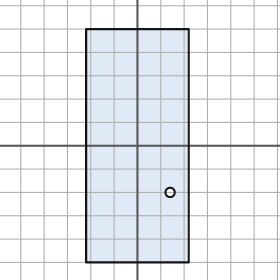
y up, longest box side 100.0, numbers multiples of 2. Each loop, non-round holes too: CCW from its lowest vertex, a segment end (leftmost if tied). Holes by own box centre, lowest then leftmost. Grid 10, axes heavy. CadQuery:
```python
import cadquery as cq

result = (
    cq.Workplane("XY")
    .moveTo(-22.0, -50.0)
    .lineTo(22.0, -50.0)
    .lineTo(22.0, 50.0)
    .lineTo(-22.0, 50.0)
    .close()
    .moveTo(14.0, -20.0)
    .circle(2.0)
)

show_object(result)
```